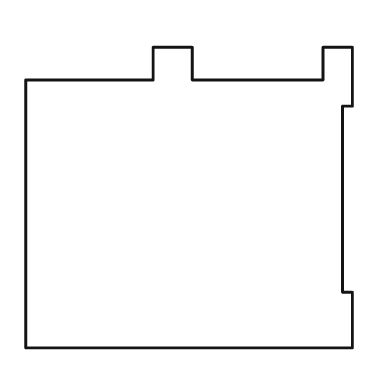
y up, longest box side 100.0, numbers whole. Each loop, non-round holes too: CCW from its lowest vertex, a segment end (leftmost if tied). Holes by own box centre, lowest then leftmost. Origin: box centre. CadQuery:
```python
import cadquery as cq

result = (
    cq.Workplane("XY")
    .moveTo(-50.0, -46.0)
    .lineTo(50.0, -46.0)
    .lineTo(50.0, -29.0)
    .lineTo(47.0, -29.0)
    .lineTo(47.0, 28.0)
    .lineTo(50.0, 28.0)
    .lineTo(50.0, 46.0)
    .lineTo(41.0, 46.0)
    .lineTo(41.0, 36.0)
    .lineTo(1.0, 36.0)
    .lineTo(1.0, 46.0)
    .lineTo(-11.0, 46.0)
    .lineTo(-11.0, 36.0)
    .lineTo(-50.0, 36.0)
    .close()
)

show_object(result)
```